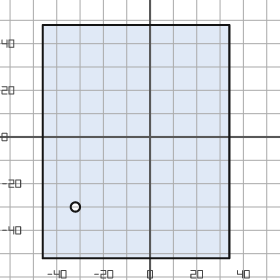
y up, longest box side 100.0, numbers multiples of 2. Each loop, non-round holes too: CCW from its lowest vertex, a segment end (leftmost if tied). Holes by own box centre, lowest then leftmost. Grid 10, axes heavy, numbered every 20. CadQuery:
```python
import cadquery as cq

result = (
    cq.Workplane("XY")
    .moveTo(-46.0, -52.0)
    .lineTo(34.0, -52.0)
    .lineTo(34.0, 48.0)
    .lineTo(-46.0, 48.0)
    .close()
    .moveTo(-32.0, -30.0)
    .circle(2.0)
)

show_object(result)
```